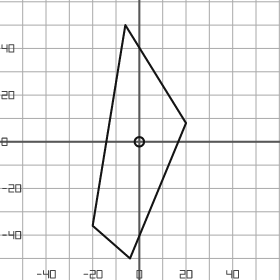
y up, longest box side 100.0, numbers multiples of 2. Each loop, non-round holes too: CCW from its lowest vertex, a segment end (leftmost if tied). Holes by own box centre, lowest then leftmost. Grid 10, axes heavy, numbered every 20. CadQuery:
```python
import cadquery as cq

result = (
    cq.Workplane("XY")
    .moveTo(-4.0, -50.0)
    .lineTo(20.0, 8.0)
    .lineTo(-6.0, 50.0)
    .lineTo(-20.0, -36.0)
    .close()
    .moveTo(0.0, 0.0)
    .circle(2.0)
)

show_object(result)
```